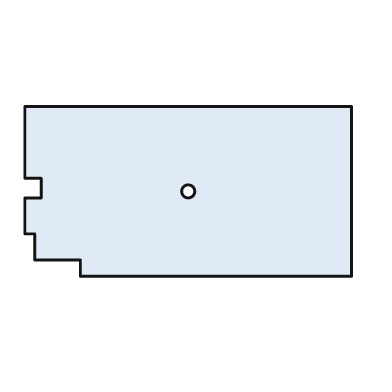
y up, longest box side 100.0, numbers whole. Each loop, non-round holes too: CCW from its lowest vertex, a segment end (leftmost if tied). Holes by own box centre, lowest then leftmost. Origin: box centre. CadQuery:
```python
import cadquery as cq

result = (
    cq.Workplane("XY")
    .moveTo(-33.0, -26.0)
    .lineTo(50.0, -26.0)
    .lineTo(50.0, 26.0)
    .lineTo(-50.0, 26.0)
    .lineTo(-50.0, 4.0)
    .lineTo(-45.0, 4.0)
    .lineTo(-45.0, -2.0)
    .lineTo(-50.0, -2.0)
    .lineTo(-50.0, -13.0)
    .lineTo(-47.0, -13.0)
    .lineTo(-47.0, -21.0)
    .lineTo(-33.0, -21.0)
    .close()
    .moveTo(0.0, 0.0)
    .circle(2.0)
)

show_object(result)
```